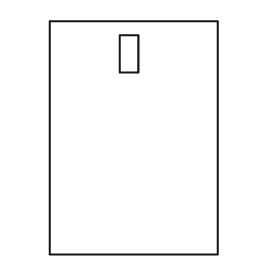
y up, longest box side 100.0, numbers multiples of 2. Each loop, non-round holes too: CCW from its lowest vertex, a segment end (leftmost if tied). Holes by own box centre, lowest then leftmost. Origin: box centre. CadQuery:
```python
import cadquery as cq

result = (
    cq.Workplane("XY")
    .moveTo(-36.0, -50.0)
    .lineTo(36.0, -50.0)
    .lineTo(36.0, 50.0)
    .lineTo(-36.0, 50.0)
    .close()
    .moveTo(-6.0, 28.0)
    .lineTo(2.0, 28.0)
    .lineTo(2.0, 44.0)
    .lineTo(-6.0, 44.0)
    .close()
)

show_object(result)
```